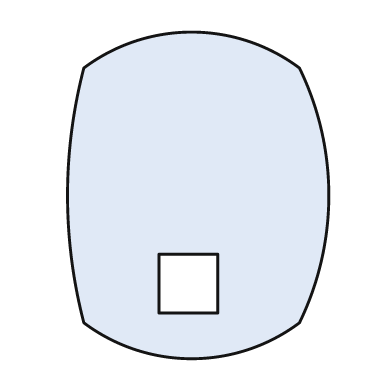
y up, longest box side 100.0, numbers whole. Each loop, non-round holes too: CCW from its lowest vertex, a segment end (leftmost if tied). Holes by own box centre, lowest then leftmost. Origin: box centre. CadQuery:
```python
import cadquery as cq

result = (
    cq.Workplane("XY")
    .moveTo(-35.0, -39.0)
    .threePointArc((-2.0, -50.0), (31.0, -39.0))
    .threePointArc((40.0, 0.0), (31.0, 39.0))
    .threePointArc((-2.0, 50.0), (-35.0, 39.0))
    .threePointArc((-40.0, 0.0), (-35.0, -39.0))
    .close()
    .moveTo(-12.0, -36.0)
    .lineTo(6.0, -36.0)
    .lineTo(6.0, -18.0)
    .lineTo(-12.0, -18.0)
    .close()
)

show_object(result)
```